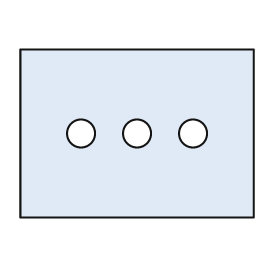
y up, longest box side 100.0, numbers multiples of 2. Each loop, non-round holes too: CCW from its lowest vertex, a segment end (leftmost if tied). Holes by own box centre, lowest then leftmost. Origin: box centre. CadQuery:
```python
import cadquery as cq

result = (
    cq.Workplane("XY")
    .moveTo(-50.0, -36.0)
    .lineTo(50.0, -36.0)
    .lineTo(50.0, 36.0)
    .lineTo(-50.0, 36.0)
    .close()
    .moveTo(-24.0, 0.0)
    .circle(6.0)
    .moveTo(0.0, 0.0)
    .circle(6.0)
    .moveTo(24.0, 0.0)
    .circle(6.0)
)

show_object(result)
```